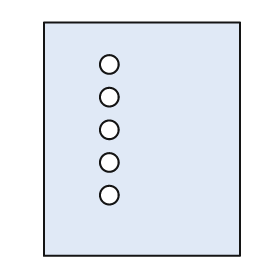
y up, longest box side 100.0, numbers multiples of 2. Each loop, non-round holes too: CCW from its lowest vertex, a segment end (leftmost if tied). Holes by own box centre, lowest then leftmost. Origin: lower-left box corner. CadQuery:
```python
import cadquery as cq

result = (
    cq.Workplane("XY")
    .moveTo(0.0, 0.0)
    .lineTo(84.0, 0.0)
    .lineTo(84.0, 100.0)
    .lineTo(0.0, 100.0)
    .close()
    .moveTo(28.0, 26.0)
    .circle(4.0)
    .moveTo(28.0, 40.0)
    .circle(4.0)
    .moveTo(28.0, 54.0)
    .circle(4.0)
    .moveTo(28.0, 68.0)
    .circle(4.0)
    .moveTo(28.0, 82.0)
    .circle(4.0)
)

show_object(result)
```